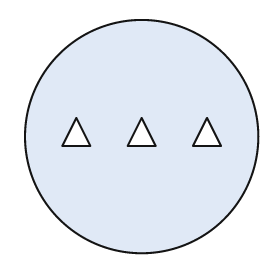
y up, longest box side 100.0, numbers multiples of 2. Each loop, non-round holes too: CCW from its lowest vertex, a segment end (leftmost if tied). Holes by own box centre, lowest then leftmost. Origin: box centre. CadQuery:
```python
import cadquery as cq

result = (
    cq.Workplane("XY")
    .moveTo(0.0, 0.0)
    .circle(50.0)
    .moveTo(-34.0, -4.0)
    .lineTo(-22.0, -4.0)
    .lineTo(-28.0, 8.0)
    .close()
    .moveTo(-6.0, -4.0)
    .lineTo(6.0, -4.0)
    .lineTo(0.0, 8.0)
    .close()
    .moveTo(22.0, -4.0)
    .lineTo(34.0, -4.0)
    .lineTo(28.0, 8.0)
    .close()
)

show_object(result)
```